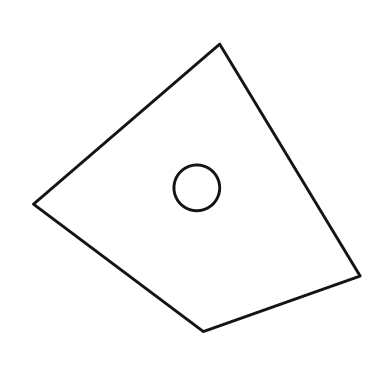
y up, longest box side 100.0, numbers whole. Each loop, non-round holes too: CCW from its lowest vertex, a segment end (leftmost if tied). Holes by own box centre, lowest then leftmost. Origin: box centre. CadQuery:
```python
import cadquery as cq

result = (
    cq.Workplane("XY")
    .moveTo(2.0, -44.0)
    .lineTo(50.0, -27.0)
    .lineTo(7.0, 44.0)
    .lineTo(-50.0, -5.0)
    .close()
    .moveTo(0.0, 0.0)
    .circle(7.0)
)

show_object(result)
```